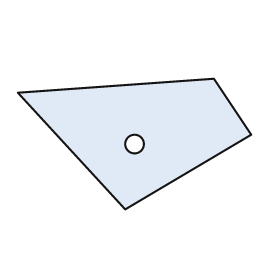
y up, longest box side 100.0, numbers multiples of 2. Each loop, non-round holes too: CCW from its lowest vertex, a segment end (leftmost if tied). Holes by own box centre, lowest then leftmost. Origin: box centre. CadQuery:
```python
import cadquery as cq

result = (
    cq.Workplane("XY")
    .moveTo(-4.0, -28.0)
    .lineTo(50.0, 4.0)
    .lineTo(34.0, 28.0)
    .lineTo(-50.0, 22.0)
    .close()
    .moveTo(0.0, 0.0)
    .circle(4.0)
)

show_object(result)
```